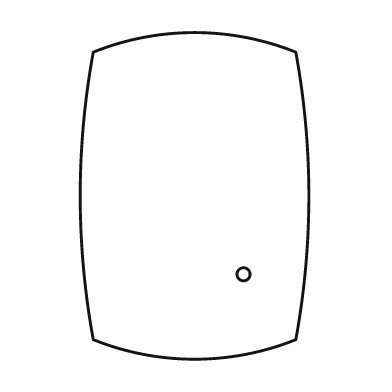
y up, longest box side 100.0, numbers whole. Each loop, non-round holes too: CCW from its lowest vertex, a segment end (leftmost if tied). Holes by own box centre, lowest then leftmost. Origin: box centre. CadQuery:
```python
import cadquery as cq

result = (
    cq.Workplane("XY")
    .moveTo(-31.0, -44.0)
    .threePointArc((0.0, -50.0), (31.0, -44.0))
    .threePointArc((35.0, 0.0), (31.0, 44.0))
    .threePointArc((0.0, 50.0), (-31.0, 44.0))
    .threePointArc((-35.0, 0.0), (-31.0, -44.0))
    .close()
    .moveTo(15.0, -24.0)
    .circle(2.0)
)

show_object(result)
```